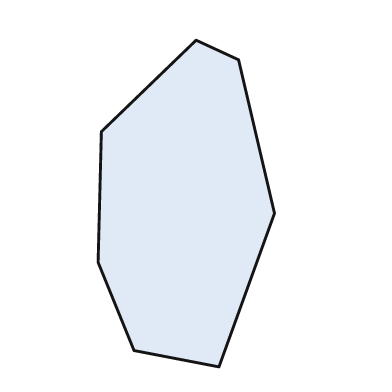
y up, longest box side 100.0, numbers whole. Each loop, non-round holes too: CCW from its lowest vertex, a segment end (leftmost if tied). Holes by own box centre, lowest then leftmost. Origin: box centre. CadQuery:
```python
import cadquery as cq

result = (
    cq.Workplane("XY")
    .moveTo(10.0, -50.0)
    .lineTo(27.0, -3.0)
    .lineTo(16.0, 44.0)
    .lineTo(3.0, 50.0)
    .lineTo(-26.0, 22.0)
    .lineTo(-27.0, -18.0)
    .lineTo(-16.0, -45.0)
    .close()
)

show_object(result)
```